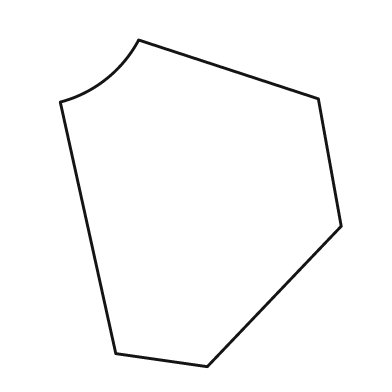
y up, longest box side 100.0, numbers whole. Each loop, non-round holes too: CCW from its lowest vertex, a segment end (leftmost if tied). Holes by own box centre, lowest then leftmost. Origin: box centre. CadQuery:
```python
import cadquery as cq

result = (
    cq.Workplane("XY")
    .moveTo(2.0, -50.0)
    .lineTo(43.0, -7.0)
    .lineTo(36.0, 32.0)
    .lineTo(-19.0, 50.0)
    .threePointArc((-29.0, 38.0), (-43.0, 31.0))
    .lineTo(-26.0, -46.0)
    .close()
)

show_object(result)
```